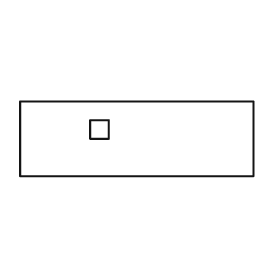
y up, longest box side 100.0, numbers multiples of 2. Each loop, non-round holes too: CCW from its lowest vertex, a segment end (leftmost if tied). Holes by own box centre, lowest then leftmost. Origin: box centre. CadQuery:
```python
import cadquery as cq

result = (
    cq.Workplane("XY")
    .moveTo(-50.0, -16.0)
    .lineTo(50.0, -16.0)
    .lineTo(50.0, 16.0)
    .lineTo(-50.0, 16.0)
    .close()
    .moveTo(-20.0, 0.0)
    .lineTo(-12.0, 0.0)
    .lineTo(-12.0, 8.0)
    .lineTo(-20.0, 8.0)
    .close()
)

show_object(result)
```